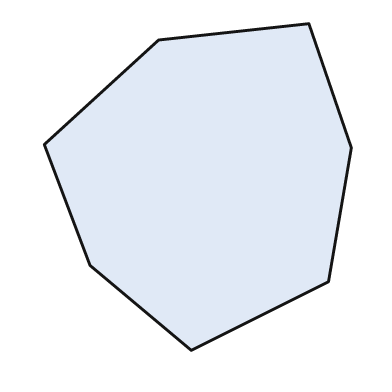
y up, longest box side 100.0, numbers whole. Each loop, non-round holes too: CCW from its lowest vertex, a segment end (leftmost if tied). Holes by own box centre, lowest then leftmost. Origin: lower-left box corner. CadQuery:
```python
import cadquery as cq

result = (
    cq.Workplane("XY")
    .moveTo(45.0, 0.0)
    .lineTo(87.0, 21.0)
    .lineTo(94.0, 62.0)
    .lineTo(81.0, 100.0)
    .lineTo(35.0, 95.0)
    .lineTo(0.0, 63.0)
    .lineTo(14.0, 26.0)
    .close()
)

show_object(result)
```